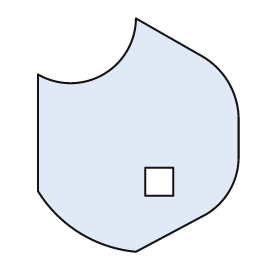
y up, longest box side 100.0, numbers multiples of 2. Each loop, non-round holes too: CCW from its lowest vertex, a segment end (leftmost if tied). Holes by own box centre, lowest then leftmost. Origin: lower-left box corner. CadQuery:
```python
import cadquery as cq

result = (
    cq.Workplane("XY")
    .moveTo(42.0, 0.0)
    .lineTo(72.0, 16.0)
    .threePointArc((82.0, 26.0), (86.0, 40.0))
    .lineTo(86.0, 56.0)
    .threePointArc((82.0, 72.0), (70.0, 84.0))
    .lineTo(42.0, 100.0)
    .threePointArc((28.0, 76.0), (0.0, 76.0))
    .lineTo(0.0, 26.0)
    .threePointArc((18.0, 8.0), (42.0, 0.0))
    .close()
    .moveTo(46.0, 24.0)
    .lineTo(58.0, 24.0)
    .lineTo(58.0, 36.0)
    .lineTo(46.0, 36.0)
    .close()
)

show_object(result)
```